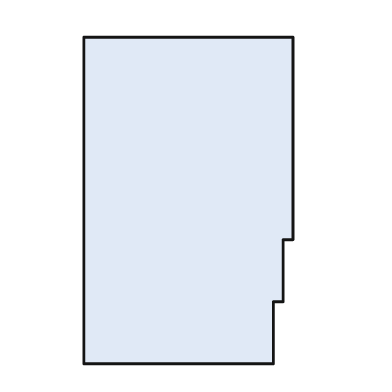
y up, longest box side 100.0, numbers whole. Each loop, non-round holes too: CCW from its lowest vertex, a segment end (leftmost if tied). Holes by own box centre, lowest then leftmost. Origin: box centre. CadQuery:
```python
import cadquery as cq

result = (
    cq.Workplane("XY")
    .moveTo(-32.0, -50.0)
    .lineTo(26.0, -50.0)
    .lineTo(26.0, -31.0)
    .lineTo(29.0, -31.0)
    .lineTo(29.0, -12.0)
    .lineTo(32.0, -12.0)
    .lineTo(32.0, 50.0)
    .lineTo(-32.0, 50.0)
    .close()
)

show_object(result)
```